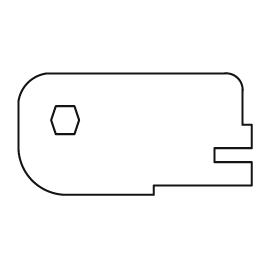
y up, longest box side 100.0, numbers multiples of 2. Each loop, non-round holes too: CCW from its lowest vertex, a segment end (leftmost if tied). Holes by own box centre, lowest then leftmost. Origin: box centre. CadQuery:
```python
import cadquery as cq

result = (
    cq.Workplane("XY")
    .moveTo(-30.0, -26.0)
    .lineTo(8.0, -26.0)
    .lineTo(8.0, -22.0)
    .lineTo(50.0, -22.0)
    .lineTo(50.0, -12.0)
    .lineTo(34.0, -12.0)
    .lineTo(34.0, -6.0)
    .lineTo(50.0, -6.0)
    .lineTo(50.0, 4.0)
    .lineTo(46.0, 4.0)
    .lineTo(46.0, 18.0)
    .threePointArc((44.0, 24.0), (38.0, 26.0))
    .lineTo(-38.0, 26.0)
    .threePointArc((-46.0, 22.0), (-50.0, 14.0))
    .lineTo(-50.0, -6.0)
    .threePointArc((-44.0, -20.0), (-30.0, -26.0))
    .close()
    .moveTo(-34.0, 0.0)
    .lineTo(-26.0, 0.0)
    .lineTo(-24.0, 6.0)
    .lineTo(-26.0, 12.0)
    .lineTo(-34.0, 12.0)
    .lineTo(-36.0, 6.0)
    .close()
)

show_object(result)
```